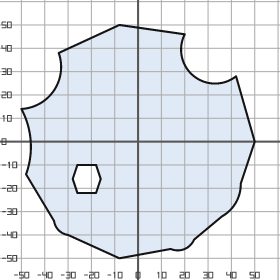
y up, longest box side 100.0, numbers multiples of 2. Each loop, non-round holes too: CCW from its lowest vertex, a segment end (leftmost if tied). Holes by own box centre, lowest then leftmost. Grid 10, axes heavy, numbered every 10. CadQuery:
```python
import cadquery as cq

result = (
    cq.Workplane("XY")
    .moveTo(-8.0, -50.0)
    .lineTo(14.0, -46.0)
    .threePointArc((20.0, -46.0), (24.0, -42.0))
    .lineTo(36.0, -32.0)
    .threePointArc((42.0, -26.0), (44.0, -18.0))
    .lineTo(50.0, 0.0)
    .lineTo(42.0, 28.0)
    .threePointArc((24.0, 28.0), (20.0, 46.0))
    .lineTo(-8.0, 50.0)
    .lineTo(-34.0, 38.0)
    .threePointArc((-36.0, 22.0), (-50.0, 14.0))
    .threePointArc((-46.0, 0.0), (-48.0, -14.0))
    .lineTo(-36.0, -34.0)
    .threePointArc((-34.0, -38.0), (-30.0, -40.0))
    .close()
    .moveTo(-26.0, -22.0)
    .lineTo(-18.0, -22.0)
    .lineTo(-16.0, -16.0)
    .lineTo(-18.0, -10.0)
    .lineTo(-26.0, -10.0)
    .lineTo(-28.0, -16.0)
    .close()
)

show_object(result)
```